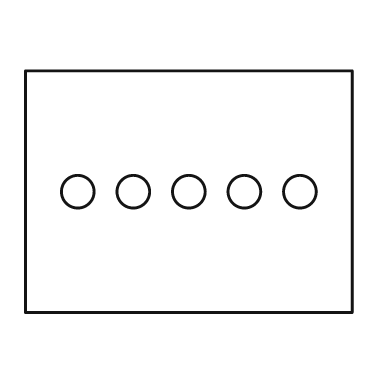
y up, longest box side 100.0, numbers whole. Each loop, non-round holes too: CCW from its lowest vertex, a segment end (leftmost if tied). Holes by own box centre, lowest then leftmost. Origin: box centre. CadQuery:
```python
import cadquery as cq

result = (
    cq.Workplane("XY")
    .moveTo(-50.0, -37.0)
    .lineTo(50.0, -37.0)
    .lineTo(50.0, 37.0)
    .lineTo(-50.0, 37.0)
    .close()
    .moveTo(-34.0, 0.0)
    .circle(5.0)
    .moveTo(-17.0, 0.0)
    .circle(5.0)
    .moveTo(0.0, 0.0)
    .circle(5.0)
    .moveTo(17.0, 0.0)
    .circle(5.0)
    .moveTo(34.0, 0.0)
    .circle(5.0)
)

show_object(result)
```